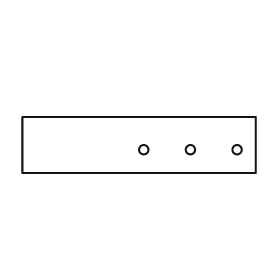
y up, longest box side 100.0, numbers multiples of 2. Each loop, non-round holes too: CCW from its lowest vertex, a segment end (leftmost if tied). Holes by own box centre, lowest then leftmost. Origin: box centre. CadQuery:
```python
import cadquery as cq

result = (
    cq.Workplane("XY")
    .moveTo(-50.0, -12.0)
    .lineTo(50.0, -12.0)
    .lineTo(50.0, 12.0)
    .lineTo(-50.0, 12.0)
    .close()
    .moveTo(2.0, -2.0)
    .circle(2.0)
    .moveTo(22.0, -2.0)
    .circle(2.0)
    .moveTo(42.0, -2.0)
    .circle(2.0)
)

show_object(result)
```